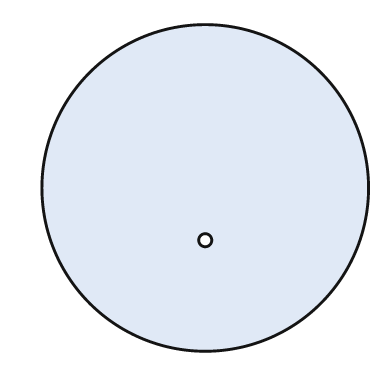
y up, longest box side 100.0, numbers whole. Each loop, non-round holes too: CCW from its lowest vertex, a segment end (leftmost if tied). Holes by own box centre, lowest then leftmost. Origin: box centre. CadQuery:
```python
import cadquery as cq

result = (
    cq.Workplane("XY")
    .moveTo(0.0, 0.0)
    .circle(50.0)
    .moveTo(0.0, -16.0)
    .circle(2.0)
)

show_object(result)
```